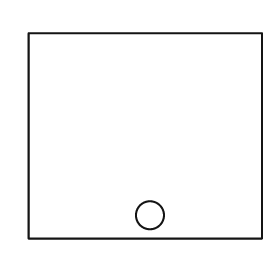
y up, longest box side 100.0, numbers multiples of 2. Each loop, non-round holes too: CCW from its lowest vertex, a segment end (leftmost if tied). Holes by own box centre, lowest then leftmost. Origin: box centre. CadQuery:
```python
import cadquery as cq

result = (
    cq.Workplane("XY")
    .moveTo(-50.0, -44.0)
    .lineTo(50.0, -44.0)
    .lineTo(50.0, 44.0)
    .lineTo(-50.0, 44.0)
    .close()
    .moveTo(2.0, -34.0)
    .circle(6.0)
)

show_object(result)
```